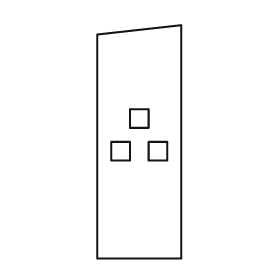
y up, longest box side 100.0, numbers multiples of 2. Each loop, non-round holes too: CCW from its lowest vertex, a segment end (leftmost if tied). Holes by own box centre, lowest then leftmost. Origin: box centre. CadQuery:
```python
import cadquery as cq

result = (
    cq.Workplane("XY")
    .moveTo(-18.0, -50.0)
    .lineTo(18.0, -50.0)
    .lineTo(18.0, 50.0)
    .lineTo(-18.0, 46.0)
    .close()
    .moveTo(-12.0, -8.0)
    .lineTo(-4.0, -8.0)
    .lineTo(-4.0, 0.0)
    .lineTo(-12.0, 0.0)
    .close()
    .moveTo(4.0, -8.0)
    .lineTo(12.0, -8.0)
    .lineTo(12.0, 0.0)
    .lineTo(4.0, 0.0)
    .close()
    .moveTo(-4.0, 6.0)
    .lineTo(4.0, 6.0)
    .lineTo(4.0, 14.0)
    .lineTo(-4.0, 14.0)
    .close()
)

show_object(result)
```